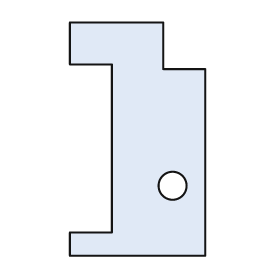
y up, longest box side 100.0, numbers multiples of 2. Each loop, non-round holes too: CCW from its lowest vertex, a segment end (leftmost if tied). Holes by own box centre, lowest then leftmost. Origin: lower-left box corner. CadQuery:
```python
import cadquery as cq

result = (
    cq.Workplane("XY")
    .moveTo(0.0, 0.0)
    .lineTo(58.0, 0.0)
    .lineTo(58.0, 80.0)
    .lineTo(40.0, 80.0)
    .lineTo(40.0, 100.0)
    .lineTo(0.0, 100.0)
    .lineTo(0.0, 82.0)
    .lineTo(18.0, 82.0)
    .lineTo(18.0, 10.0)
    .lineTo(0.0, 10.0)
    .close()
    .moveTo(44.0, 30.0)
    .circle(6.0)
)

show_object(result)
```